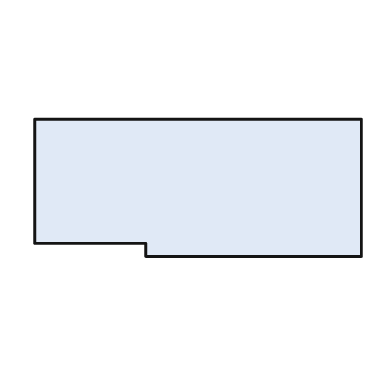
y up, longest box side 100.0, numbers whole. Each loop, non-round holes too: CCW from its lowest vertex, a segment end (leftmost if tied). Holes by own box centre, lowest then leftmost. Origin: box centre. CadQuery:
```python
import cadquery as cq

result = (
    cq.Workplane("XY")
    .moveTo(-16.0, -21.0)
    .lineTo(50.0, -21.0)
    .lineTo(50.0, 21.0)
    .lineTo(-50.0, 21.0)
    .lineTo(-50.0, -17.0)
    .lineTo(-16.0, -17.0)
    .close()
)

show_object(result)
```